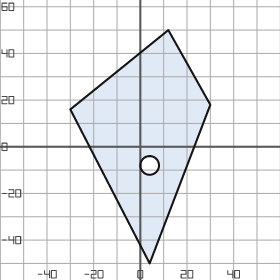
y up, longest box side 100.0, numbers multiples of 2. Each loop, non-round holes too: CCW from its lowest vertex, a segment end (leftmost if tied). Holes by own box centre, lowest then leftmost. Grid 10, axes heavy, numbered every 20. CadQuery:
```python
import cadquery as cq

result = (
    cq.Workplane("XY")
    .moveTo(4.0, -50.0)
    .lineTo(30.0, 18.0)
    .lineTo(12.0, 50.0)
    .lineTo(-30.0, 16.0)
    .close()
    .moveTo(4.0, -8.0)
    .circle(4.0)
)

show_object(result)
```